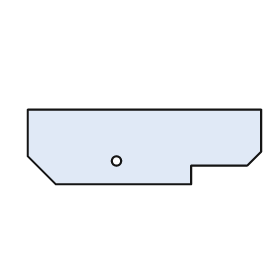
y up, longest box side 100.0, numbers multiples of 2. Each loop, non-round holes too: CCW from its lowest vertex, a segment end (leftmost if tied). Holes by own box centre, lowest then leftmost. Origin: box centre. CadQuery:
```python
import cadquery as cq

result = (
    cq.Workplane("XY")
    .moveTo(-38.0, -16.0)
    .lineTo(20.0, -16.0)
    .lineTo(20.0, -8.0)
    .lineTo(44.0, -8.0)
    .lineTo(50.0, -2.0)
    .lineTo(50.0, 16.0)
    .lineTo(-50.0, 16.0)
    .lineTo(-50.0, -4.0)
    .close()
    .moveTo(-12.0, -6.0)
    .circle(2.0)
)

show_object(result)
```